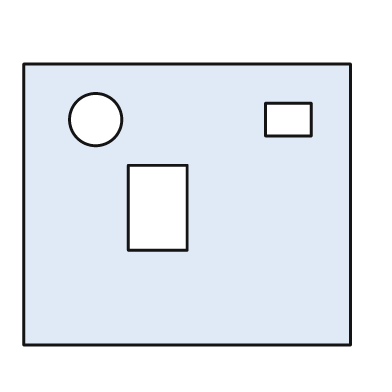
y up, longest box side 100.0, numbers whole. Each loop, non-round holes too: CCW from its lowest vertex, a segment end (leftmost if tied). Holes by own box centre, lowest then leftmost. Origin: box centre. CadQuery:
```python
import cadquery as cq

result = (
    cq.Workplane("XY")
    .moveTo(-50.0, -43.0)
    .lineTo(50.0, -43.0)
    .lineTo(50.0, 43.0)
    .lineTo(-50.0, 43.0)
    .close()
    .moveTo(-18.0, -14.0)
    .lineTo(0.0, -14.0)
    .lineTo(0.0, 12.0)
    .lineTo(-18.0, 12.0)
    .close()
    .moveTo(-28.0, 26.0)
    .circle(8.0)
    .moveTo(24.0, 21.0)
    .lineTo(38.0, 21.0)
    .lineTo(38.0, 31.0)
    .lineTo(24.0, 31.0)
    .close()
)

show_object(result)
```